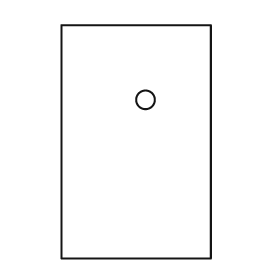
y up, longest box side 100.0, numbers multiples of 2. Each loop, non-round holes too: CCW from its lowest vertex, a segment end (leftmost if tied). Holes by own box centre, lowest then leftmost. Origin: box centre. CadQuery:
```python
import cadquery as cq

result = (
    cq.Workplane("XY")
    .moveTo(-32.0, -50.0)
    .lineTo(32.0, -50.0)
    .lineTo(32.0, 50.0)
    .lineTo(-32.0, 50.0)
    .close()
    .moveTo(4.0, 18.0)
    .circle(4.0)
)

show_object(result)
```